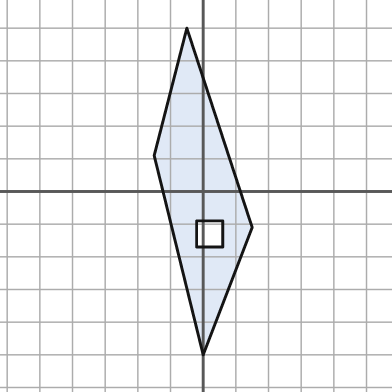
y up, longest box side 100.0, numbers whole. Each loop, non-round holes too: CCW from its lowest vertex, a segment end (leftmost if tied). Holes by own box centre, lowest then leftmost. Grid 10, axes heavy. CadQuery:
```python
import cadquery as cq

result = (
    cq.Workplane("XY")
    .moveTo(0.0, -50.0)
    .lineTo(15.0, -11.0)
    .lineTo(-5.0, 50.0)
    .lineTo(-15.0, 11.0)
    .close()
    .moveTo(-2.0, -17.0)
    .lineTo(6.0, -17.0)
    .lineTo(6.0, -9.0)
    .lineTo(-2.0, -9.0)
    .close()
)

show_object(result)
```